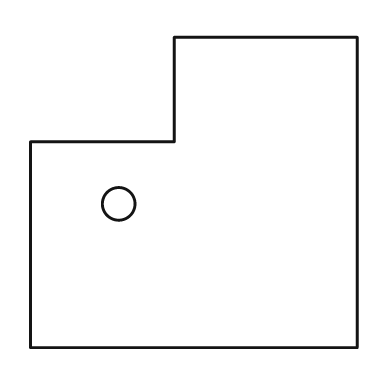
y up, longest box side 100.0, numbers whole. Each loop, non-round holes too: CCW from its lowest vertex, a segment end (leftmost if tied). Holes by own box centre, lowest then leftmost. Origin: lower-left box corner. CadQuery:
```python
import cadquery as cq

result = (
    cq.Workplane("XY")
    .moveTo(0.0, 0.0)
    .lineTo(100.0, 0.0)
    .lineTo(100.0, 95.0)
    .lineTo(44.0, 95.0)
    .lineTo(44.0, 63.0)
    .lineTo(0.0, 63.0)
    .close()
    .moveTo(27.0, 44.0)
    .circle(5.0)
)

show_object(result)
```